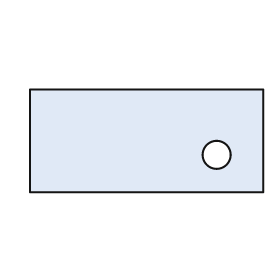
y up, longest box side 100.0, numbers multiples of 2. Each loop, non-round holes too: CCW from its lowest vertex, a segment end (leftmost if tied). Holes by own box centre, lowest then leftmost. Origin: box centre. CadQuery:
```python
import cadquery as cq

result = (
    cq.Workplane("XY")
    .moveTo(-50.0, -22.0)
    .lineTo(50.0, -22.0)
    .lineTo(50.0, 22.0)
    .lineTo(-50.0, 22.0)
    .close()
    .moveTo(30.0, -6.0)
    .circle(6.0)
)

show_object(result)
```